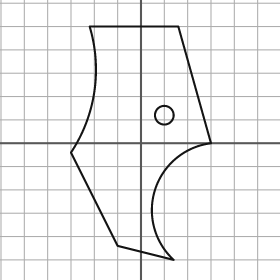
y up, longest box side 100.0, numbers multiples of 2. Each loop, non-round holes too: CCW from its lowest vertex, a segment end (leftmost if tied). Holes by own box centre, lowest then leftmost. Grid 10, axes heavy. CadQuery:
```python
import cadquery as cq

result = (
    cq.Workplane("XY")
    .moveTo(14.0, -50.0)
    .threePointArc((6.0, -20.0), (30.0, 0.0))
    .lineTo(16.0, 50.0)
    .lineTo(-22.0, 50.0)
    .threePointArc((-20.0, 22.0), (-30.0, -4.0))
    .lineTo(-10.0, -44.0)
    .close()
    .moveTo(10.0, 12.0)
    .circle(4.0)
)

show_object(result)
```